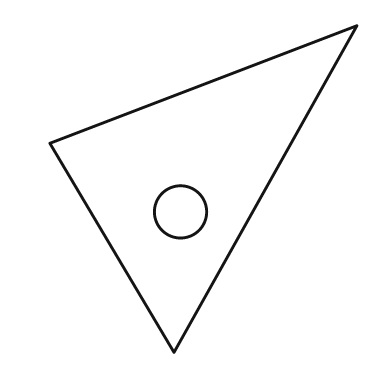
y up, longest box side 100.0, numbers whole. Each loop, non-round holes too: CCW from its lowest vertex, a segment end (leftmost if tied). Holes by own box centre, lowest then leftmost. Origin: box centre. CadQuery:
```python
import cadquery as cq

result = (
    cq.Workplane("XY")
    .moveTo(-9.0, -50.0)
    .lineTo(47.0, 50.0)
    .lineTo(-47.0, 14.0)
    .close()
    .moveTo(-7.0, -7.0)
    .circle(8.0)
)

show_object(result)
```